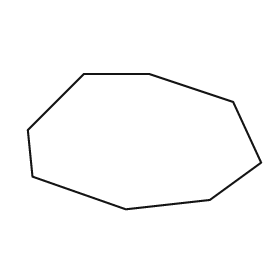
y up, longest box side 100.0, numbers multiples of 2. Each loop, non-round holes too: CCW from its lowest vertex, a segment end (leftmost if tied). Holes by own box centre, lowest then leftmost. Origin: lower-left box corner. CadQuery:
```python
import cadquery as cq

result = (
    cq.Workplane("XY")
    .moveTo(42.0, 0.0)
    .lineTo(78.0, 4.0)
    .lineTo(100.0, 20.0)
    .lineTo(88.0, 46.0)
    .lineTo(52.0, 58.0)
    .lineTo(24.0, 58.0)
    .lineTo(0.0, 34.0)
    .lineTo(2.0, 14.0)
    .close()
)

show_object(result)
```